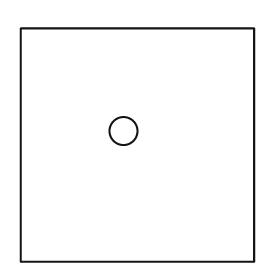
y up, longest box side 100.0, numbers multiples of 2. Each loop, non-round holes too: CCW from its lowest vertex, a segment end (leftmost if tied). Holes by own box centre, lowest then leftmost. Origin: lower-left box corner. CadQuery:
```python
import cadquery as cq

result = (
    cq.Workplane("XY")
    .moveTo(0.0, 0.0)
    .lineTo(100.0, 0.0)
    .lineTo(100.0, 100.0)
    .lineTo(0.0, 100.0)
    .close()
    .moveTo(44.0, 56.0)
    .circle(6.0)
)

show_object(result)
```